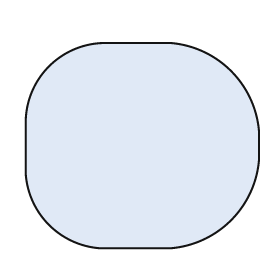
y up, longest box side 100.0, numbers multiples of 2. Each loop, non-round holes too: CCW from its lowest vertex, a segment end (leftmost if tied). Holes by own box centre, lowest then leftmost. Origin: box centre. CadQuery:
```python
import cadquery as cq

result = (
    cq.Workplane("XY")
    .moveTo(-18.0, -44.0)
    .lineTo(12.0, -44.0)
    .threePointArc((38.0, -32.0), (50.0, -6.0))
    .lineTo(50.0, 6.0)
    .threePointArc((38.0, 32.0), (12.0, 44.0))
    .lineTo(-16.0, 44.0)
    .threePointArc((-40.0, 34.0), (-50.0, 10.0))
    .lineTo(-50.0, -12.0)
    .threePointArc((-40.0, -34.0), (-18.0, -44.0))
    .close()
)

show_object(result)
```